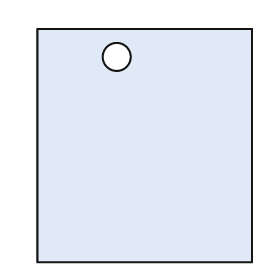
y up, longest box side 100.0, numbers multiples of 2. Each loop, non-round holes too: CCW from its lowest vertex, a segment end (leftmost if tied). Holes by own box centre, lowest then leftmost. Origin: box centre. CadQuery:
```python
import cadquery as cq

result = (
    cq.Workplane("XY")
    .moveTo(-46.0, -50.0)
    .lineTo(46.0, -50.0)
    .lineTo(46.0, 50.0)
    .lineTo(-46.0, 50.0)
    .close()
    .moveTo(-12.0, 38.0)
    .circle(6.0)
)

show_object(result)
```